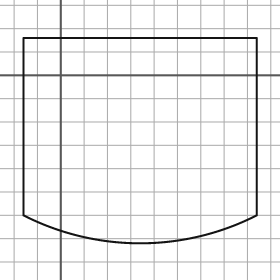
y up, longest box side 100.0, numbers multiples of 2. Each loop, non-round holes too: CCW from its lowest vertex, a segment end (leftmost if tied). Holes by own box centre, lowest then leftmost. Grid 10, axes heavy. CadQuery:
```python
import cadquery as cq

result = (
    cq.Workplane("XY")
    .moveTo(-16.0, -60.0)
    .threePointArc((34.0, -72.0), (84.0, -60.0))
    .lineTo(84.0, 16.0)
    .lineTo(-16.0, 16.0)
    .close()
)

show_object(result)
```